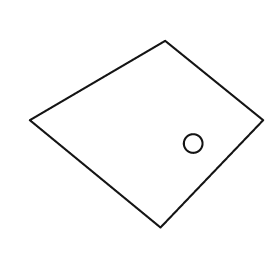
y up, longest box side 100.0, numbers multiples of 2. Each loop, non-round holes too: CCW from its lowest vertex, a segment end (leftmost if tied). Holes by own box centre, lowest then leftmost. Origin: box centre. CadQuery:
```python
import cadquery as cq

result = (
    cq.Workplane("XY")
    .moveTo(6.0, -40.0)
    .lineTo(50.0, 6.0)
    .lineTo(8.0, 40.0)
    .lineTo(-50.0, 6.0)
    .close()
    .moveTo(20.0, -4.0)
    .circle(4.0)
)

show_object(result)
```